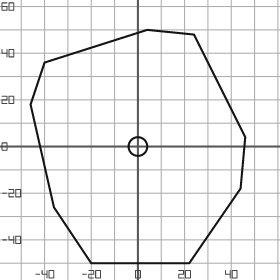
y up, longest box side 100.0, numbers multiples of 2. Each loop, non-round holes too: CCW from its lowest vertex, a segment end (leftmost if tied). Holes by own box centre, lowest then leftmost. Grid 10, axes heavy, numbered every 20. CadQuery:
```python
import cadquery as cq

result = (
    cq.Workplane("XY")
    .moveTo(-20.0, -50.0)
    .lineTo(22.0, -50.0)
    .lineTo(44.0, -18.0)
    .lineTo(46.0, 4.0)
    .lineTo(24.0, 48.0)
    .lineTo(4.0, 50.0)
    .lineTo(-40.0, 36.0)
    .lineTo(-46.0, 18.0)
    .lineTo(-36.0, -26.0)
    .close()
    .moveTo(0.0, 0.0)
    .circle(4.0)
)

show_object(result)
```